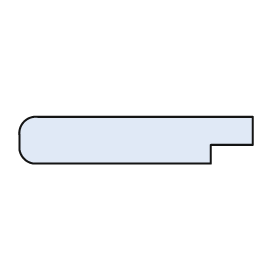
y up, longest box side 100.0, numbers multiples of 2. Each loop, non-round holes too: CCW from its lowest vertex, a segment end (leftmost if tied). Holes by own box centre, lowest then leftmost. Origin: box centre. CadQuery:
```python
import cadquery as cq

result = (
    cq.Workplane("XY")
    .moveTo(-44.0, -10.0)
    .lineTo(32.0, -10.0)
    .lineTo(32.0, -2.0)
    .lineTo(50.0, -2.0)
    .lineTo(50.0, 10.0)
    .lineTo(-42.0, 10.0)
    .threePointArc((-48.0, 8.0), (-50.0, 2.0))
    .lineTo(-50.0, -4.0)
    .threePointArc((-48.0, -8.0), (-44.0, -10.0))
    .close()
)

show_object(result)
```